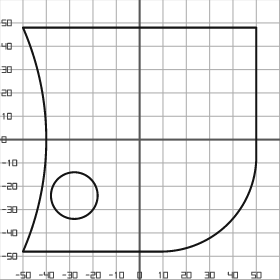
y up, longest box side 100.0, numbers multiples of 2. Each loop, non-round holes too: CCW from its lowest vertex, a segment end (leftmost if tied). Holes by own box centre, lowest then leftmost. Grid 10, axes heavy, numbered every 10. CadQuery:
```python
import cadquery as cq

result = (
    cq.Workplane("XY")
    .moveTo(-50.0, -48.0)
    .lineTo(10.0, -48.0)
    .threePointArc((38.0, -36.0), (50.0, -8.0))
    .lineTo(50.0, 48.0)
    .lineTo(-50.0, 48.0)
    .threePointArc((-40.0, 0.0), (-50.0, -48.0))
    .close()
    .moveTo(-28.0, -24.0)
    .circle(10.0)
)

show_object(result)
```